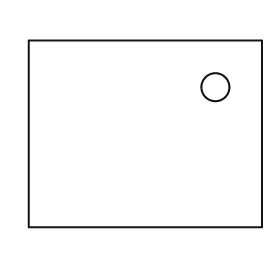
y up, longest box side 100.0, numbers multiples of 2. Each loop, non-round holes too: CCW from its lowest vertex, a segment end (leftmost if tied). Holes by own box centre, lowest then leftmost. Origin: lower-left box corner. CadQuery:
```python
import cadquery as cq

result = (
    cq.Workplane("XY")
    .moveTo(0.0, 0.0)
    .lineTo(100.0, 0.0)
    .lineTo(100.0, 80.0)
    .lineTo(0.0, 80.0)
    .close()
    .moveTo(80.0, 60.0)
    .circle(6.0)
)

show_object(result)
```